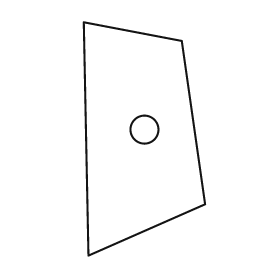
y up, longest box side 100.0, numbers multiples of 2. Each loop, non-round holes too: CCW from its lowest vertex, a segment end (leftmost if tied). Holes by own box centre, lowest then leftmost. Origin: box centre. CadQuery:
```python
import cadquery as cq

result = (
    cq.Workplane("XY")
    .moveTo(-24.0, -50.0)
    .lineTo(26.0, -28.0)
    .lineTo(16.0, 42.0)
    .lineTo(-26.0, 50.0)
    .close()
    .moveTo(0.0, 4.0)
    .circle(6.0)
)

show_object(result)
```